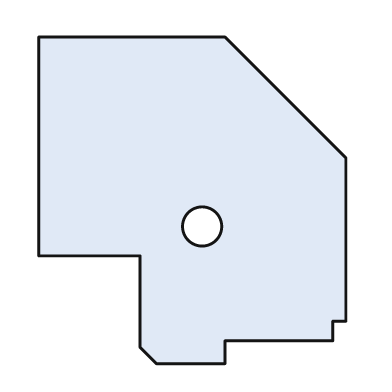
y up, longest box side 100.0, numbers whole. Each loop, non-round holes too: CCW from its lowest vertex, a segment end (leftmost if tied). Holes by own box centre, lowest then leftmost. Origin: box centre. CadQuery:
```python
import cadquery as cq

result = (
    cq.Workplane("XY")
    .moveTo(-11.0, -50.0)
    .lineTo(10.0, -50.0)
    .lineTo(10.0, -43.0)
    .lineTo(43.0, -43.0)
    .lineTo(43.0, -37.0)
    .lineTo(47.0, -37.0)
    .lineTo(47.0, 13.0)
    .lineTo(10.0, 50.0)
    .lineTo(-47.0, 50.0)
    .lineTo(-47.0, -17.0)
    .lineTo(-16.0, -17.0)
    .lineTo(-16.0, -45.0)
    .close()
    .moveTo(3.0, -8.0)
    .circle(6.0)
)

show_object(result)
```